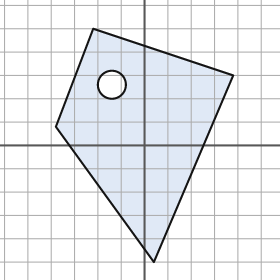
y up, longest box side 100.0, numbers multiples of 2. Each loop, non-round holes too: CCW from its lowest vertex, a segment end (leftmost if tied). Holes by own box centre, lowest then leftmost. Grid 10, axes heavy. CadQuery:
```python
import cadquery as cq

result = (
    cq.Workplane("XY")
    .moveTo(4.0, -50.0)
    .lineTo(38.0, 30.0)
    .lineTo(-22.0, 50.0)
    .lineTo(-38.0, 8.0)
    .close()
    .moveTo(-14.0, 26.0)
    .circle(6.0)
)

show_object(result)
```